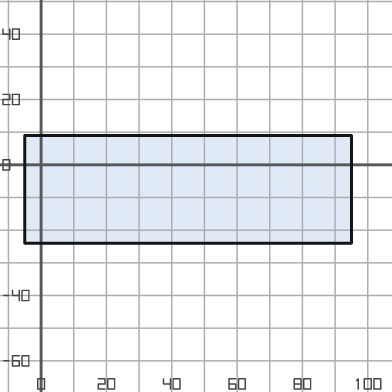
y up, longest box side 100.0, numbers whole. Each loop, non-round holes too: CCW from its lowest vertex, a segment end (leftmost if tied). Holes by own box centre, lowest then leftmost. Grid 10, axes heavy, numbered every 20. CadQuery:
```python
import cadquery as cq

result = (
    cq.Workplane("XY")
    .moveTo(-5.0, -24.0)
    .lineTo(95.0, -24.0)
    .lineTo(95.0, 9.0)
    .lineTo(-5.0, 9.0)
    .close()
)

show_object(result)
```